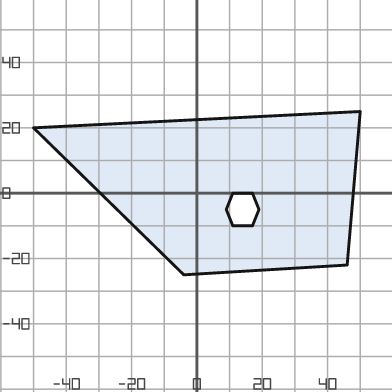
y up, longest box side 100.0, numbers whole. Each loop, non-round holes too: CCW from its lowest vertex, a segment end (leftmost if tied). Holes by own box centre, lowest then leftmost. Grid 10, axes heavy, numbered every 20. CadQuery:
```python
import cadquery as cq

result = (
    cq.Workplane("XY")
    .moveTo(-4.0, -25.0)
    .lineTo(46.0, -22.0)
    .lineTo(50.0, 25.0)
    .lineTo(-50.0, 20.0)
    .close()
    .moveTo(11.0, -10.0)
    .lineTo(17.0, -10.0)
    .lineTo(19.0, -5.0)
    .lineTo(17.0, 0.0)
    .lineTo(11.0, 0.0)
    .lineTo(9.0, -5.0)
    .close()
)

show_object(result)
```